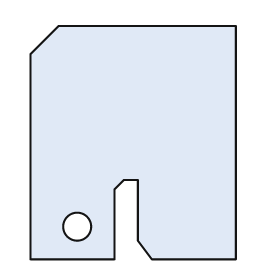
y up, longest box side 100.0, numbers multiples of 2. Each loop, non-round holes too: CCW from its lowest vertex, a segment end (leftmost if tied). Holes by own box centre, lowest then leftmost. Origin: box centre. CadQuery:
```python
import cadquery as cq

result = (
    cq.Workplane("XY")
    .moveTo(-44.0, -50.0)
    .lineTo(-8.0, -50.0)
    .lineTo(-8.0, -20.0)
    .lineTo(-4.0, -16.0)
    .lineTo(2.0, -16.0)
    .lineTo(2.0, -42.0)
    .lineTo(8.0, -50.0)
    .lineTo(44.0, -50.0)
    .lineTo(44.0, 50.0)
    .lineTo(-32.0, 50.0)
    .lineTo(-44.0, 38.0)
    .close()
    .moveTo(-24.0, -36.0)
    .circle(6.0)
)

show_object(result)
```